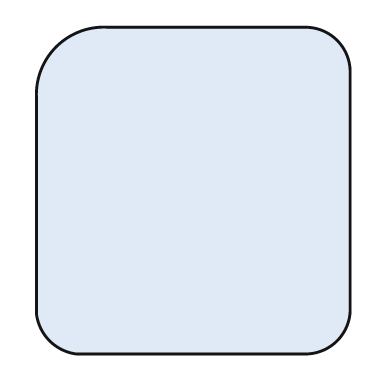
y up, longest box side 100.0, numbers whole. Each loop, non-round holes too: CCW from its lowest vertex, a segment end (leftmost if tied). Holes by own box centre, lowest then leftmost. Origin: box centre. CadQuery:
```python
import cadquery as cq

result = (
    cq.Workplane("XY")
    .moveTo(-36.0, -50.0)
    .lineTo(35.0, -50.0)
    .threePointArc((44.0, -46.0), (48.0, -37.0))
    .lineTo(48.0, 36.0)
    .threePointArc((44.0, 46.0), (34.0, 50.0))
    .lineTo(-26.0, 50.0)
    .threePointArc((-42.0, 44.0), (-48.0, 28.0))
    .lineTo(-48.0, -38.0)
    .threePointArc((-44.0, -46.0), (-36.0, -50.0))
    .close()
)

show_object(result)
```